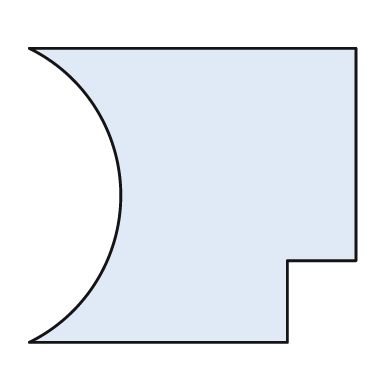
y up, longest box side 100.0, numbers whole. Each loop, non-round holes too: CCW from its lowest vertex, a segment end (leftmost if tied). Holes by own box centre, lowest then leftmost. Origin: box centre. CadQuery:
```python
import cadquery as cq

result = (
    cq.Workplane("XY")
    .moveTo(-50.0, -45.0)
    .lineTo(29.0, -45.0)
    .lineTo(29.0, -20.0)
    .lineTo(50.0, -20.0)
    .lineTo(50.0, 45.0)
    .lineTo(-50.0, 45.0)
    .threePointArc((-22.0, 0.0), (-50.0, -45.0))
    .close()
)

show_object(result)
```